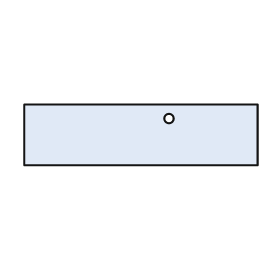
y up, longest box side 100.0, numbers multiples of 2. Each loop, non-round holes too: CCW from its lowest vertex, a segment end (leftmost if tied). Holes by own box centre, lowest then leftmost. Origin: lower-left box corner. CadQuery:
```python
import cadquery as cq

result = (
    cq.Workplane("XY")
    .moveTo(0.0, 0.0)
    .lineTo(100.0, 0.0)
    .lineTo(100.0, 26.0)
    .lineTo(0.0, 26.0)
    .close()
    .moveTo(62.0, 20.0)
    .circle(2.0)
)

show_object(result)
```